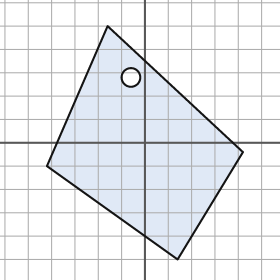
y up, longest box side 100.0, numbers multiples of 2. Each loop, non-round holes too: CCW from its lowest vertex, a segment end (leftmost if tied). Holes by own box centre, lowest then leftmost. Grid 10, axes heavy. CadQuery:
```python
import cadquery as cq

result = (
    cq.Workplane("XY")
    .moveTo(14.0, -50.0)
    .lineTo(42.0, -4.0)
    .lineTo(-16.0, 50.0)
    .lineTo(-42.0, -10.0)
    .close()
    .moveTo(-6.0, 28.0)
    .circle(4.0)
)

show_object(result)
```